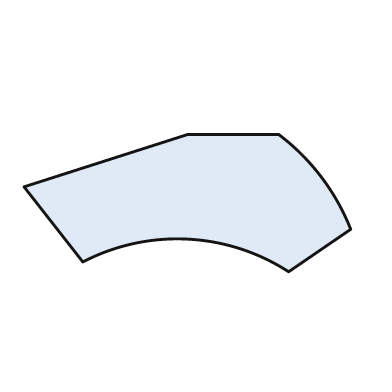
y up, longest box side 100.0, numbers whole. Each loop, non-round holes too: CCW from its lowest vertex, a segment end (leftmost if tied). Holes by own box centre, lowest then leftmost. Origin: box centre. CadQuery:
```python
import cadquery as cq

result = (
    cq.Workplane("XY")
    .moveTo(31.0, -21.0)
    .lineTo(50.0, -8.0)
    .threePointArc((41.0, 8.0), (28.0, 21.0))
    .lineTo(0.0, 21.0)
    .lineTo(-50.0, 5.0)
    .lineTo(-32.0, -18.0)
    .threePointArc((0.0, -11.0), (31.0, -21.0))
    .close()
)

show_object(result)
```